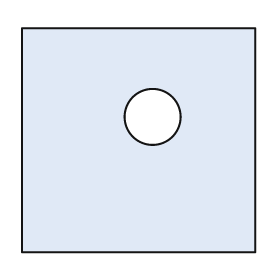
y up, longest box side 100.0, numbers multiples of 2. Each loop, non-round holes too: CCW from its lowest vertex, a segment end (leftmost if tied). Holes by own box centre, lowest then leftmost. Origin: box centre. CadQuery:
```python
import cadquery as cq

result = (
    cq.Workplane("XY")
    .moveTo(-50.0, -48.0)
    .lineTo(50.0, -48.0)
    .lineTo(50.0, 48.0)
    .lineTo(-50.0, 48.0)
    .close()
    .moveTo(6.0, 10.0)
    .circle(12.0)
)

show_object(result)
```